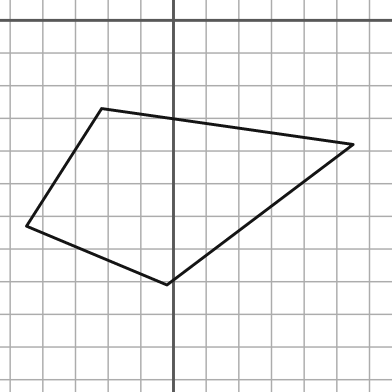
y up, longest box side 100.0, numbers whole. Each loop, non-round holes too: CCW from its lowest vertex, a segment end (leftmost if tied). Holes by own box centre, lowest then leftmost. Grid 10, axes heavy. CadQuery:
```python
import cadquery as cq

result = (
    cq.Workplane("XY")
    .moveTo(-2.0, -81.0)
    .lineTo(55.0, -38.0)
    .lineTo(-22.0, -27.0)
    .lineTo(-45.0, -63.0)
    .close()
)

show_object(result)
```